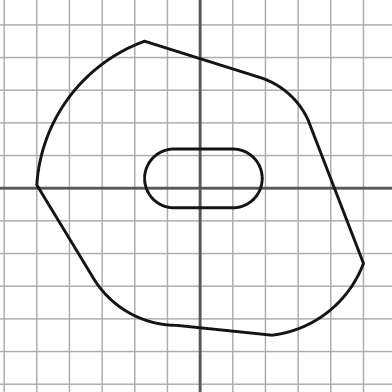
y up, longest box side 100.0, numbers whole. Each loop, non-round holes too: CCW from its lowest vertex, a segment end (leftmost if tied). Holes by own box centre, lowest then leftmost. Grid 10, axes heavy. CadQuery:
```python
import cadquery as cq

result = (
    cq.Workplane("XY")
    .moveTo(22.0, -45.0)
    .threePointArc((39.0, -38.0), (50.0, -23.0))
    .lineTo(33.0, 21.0)
    .threePointArc((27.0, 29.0), (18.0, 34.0))
    .lineTo(-17.0, 45.0)
    .threePointArc((-40.0, 28.0), (-50.0, 1.0))
    .lineTo(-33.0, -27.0)
    .threePointArc((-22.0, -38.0), (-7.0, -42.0))
    .close()
    .moveTo(-8.0, -6.0)
    .lineTo(10.0, -6.0)
    .threePointArc((19.0, 3.0), (10.0, 12.0))
    .lineTo(-8.0, 12.0)
    .threePointArc((-17.0, 3.0), (-8.0, -6.0))
    .close()
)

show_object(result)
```